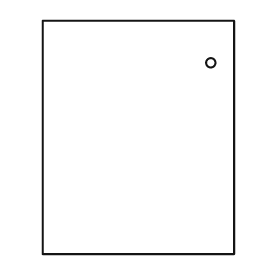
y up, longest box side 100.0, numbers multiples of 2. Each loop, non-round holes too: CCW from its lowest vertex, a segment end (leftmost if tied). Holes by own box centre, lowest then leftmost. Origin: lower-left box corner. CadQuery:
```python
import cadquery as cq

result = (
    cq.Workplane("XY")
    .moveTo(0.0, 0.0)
    .lineTo(82.0, 0.0)
    .lineTo(82.0, 100.0)
    .lineTo(0.0, 100.0)
    .close()
    .moveTo(72.0, 82.0)
    .circle(2.0)
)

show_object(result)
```